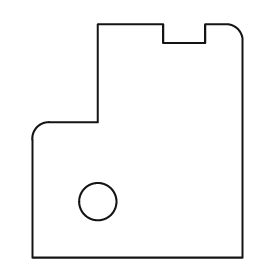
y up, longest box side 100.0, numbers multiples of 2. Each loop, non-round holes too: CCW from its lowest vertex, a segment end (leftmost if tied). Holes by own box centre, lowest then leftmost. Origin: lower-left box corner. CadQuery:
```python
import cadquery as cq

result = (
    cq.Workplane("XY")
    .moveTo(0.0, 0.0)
    .lineTo(90.0, 0.0)
    .lineTo(90.0, 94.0)
    .threePointArc((88.0, 98.0), (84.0, 100.0))
    .lineTo(74.0, 100.0)
    .lineTo(74.0, 92.0)
    .lineTo(56.0, 92.0)
    .lineTo(56.0, 100.0)
    .lineTo(28.0, 100.0)
    .lineTo(28.0, 58.0)
    .lineTo(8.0, 58.0)
    .threePointArc((2.0, 56.0), (0.0, 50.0))
    .close()
    .moveTo(28.0, 24.0)
    .circle(8.0)
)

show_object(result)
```